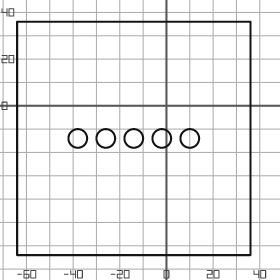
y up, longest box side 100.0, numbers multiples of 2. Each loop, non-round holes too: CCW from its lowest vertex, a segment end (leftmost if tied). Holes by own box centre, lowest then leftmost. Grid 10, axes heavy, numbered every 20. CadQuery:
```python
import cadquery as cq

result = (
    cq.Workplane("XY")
    .moveTo(-64.0, -64.0)
    .lineTo(36.0, -64.0)
    .lineTo(36.0, 36.0)
    .lineTo(-64.0, 36.0)
    .close()
    .moveTo(-38.0, -14.0)
    .circle(4.0)
    .moveTo(-26.0, -14.0)
    .circle(4.0)
    .moveTo(-14.0, -14.0)
    .circle(4.0)
    .moveTo(-2.0, -14.0)
    .circle(4.0)
    .moveTo(10.0, -14.0)
    .circle(4.0)
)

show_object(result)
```